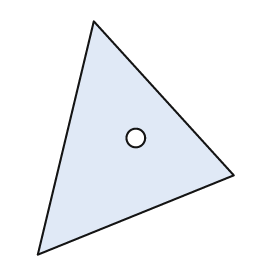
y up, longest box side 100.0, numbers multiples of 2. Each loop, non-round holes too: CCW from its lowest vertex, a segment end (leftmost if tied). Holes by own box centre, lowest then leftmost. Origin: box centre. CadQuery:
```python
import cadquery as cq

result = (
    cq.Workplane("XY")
    .moveTo(-42.0, -50.0)
    .lineTo(42.0, -16.0)
    .lineTo(-18.0, 50.0)
    .close()
    .moveTo(0.0, 0.0)
    .circle(4.0)
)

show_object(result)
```